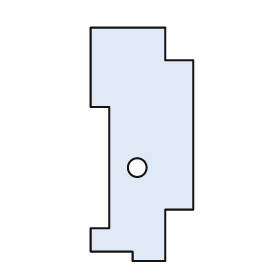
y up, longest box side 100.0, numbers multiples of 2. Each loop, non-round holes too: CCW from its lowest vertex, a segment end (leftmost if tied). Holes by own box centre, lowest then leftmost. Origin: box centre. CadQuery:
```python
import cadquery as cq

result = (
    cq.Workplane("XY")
    .moveTo(-4.0, -50.0)
    .lineTo(10.0, -50.0)
    .lineTo(10.0, -28.0)
    .lineTo(22.0, -28.0)
    .lineTo(22.0, 36.0)
    .lineTo(10.0, 36.0)
    .lineTo(10.0, 50.0)
    .lineTo(-22.0, 50.0)
    .lineTo(-22.0, 16.0)
    .lineTo(-14.0, 16.0)
    .lineTo(-14.0, -36.0)
    .lineTo(-22.0, -36.0)
    .lineTo(-22.0, -46.0)
    .lineTo(-4.0, -46.0)
    .close()
    .moveTo(-2.0, -10.0)
    .circle(4.0)
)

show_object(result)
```